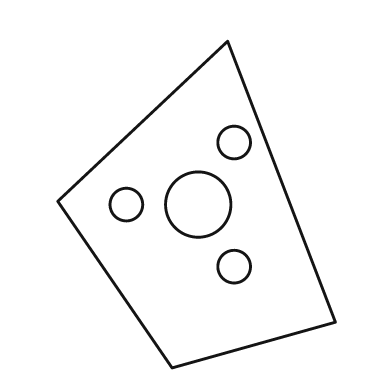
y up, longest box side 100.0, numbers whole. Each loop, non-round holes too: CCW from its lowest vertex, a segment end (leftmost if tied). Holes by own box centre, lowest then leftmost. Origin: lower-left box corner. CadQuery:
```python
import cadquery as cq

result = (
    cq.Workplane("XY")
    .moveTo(35.0, 0.0)
    .lineTo(85.0, 14.0)
    .lineTo(52.0, 100.0)
    .lineTo(0.0, 51.0)
    .close()
    .moveTo(54.0, 31.0)
    .circle(5.0)
    .moveTo(21.0, 50.0)
    .circle(5.0)
    .moveTo(43.0, 50.0)
    .circle(10.0)
    .moveTo(54.0, 69.0)
    .circle(5.0)
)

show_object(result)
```